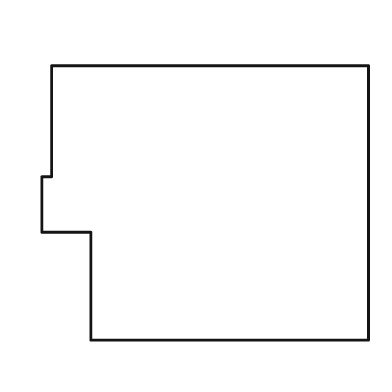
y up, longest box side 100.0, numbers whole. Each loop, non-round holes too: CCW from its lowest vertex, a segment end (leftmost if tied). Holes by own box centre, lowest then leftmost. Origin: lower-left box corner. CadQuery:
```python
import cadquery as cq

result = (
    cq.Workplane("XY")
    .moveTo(15.0, 0.0)
    .lineTo(100.0, 0.0)
    .lineTo(100.0, 84.0)
    .lineTo(3.0, 84.0)
    .lineTo(3.0, 50.0)
    .lineTo(0.0, 50.0)
    .lineTo(0.0, 33.0)
    .lineTo(15.0, 33.0)
    .close()
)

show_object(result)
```